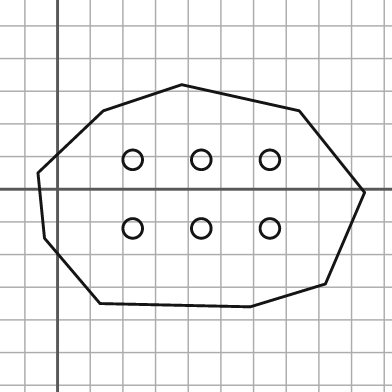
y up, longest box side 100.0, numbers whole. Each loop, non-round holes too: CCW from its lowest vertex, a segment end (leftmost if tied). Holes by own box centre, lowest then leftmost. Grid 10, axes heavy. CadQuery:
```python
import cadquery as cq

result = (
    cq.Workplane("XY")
    .moveTo(59.0, -36.0)
    .lineTo(82.0, -29.0)
    .lineTo(94.0, -1.0)
    .lineTo(74.0, 24.0)
    .lineTo(38.0, 32.0)
    .lineTo(14.0, 24.0)
    .lineTo(-6.0, 5.0)
    .lineTo(-4.0, -15.0)
    .lineTo(13.0, -35.0)
    .close()
    .moveTo(23.0, -12.0)
    .circle(3.0)
    .moveTo(44.0, -12.0)
    .circle(3.0)
    .moveTo(65.0, -12.0)
    .circle(3.0)
    .moveTo(23.0, 9.0)
    .circle(3.0)
    .moveTo(44.0, 9.0)
    .circle(3.0)
    .moveTo(65.0, 9.0)
    .circle(3.0)
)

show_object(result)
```